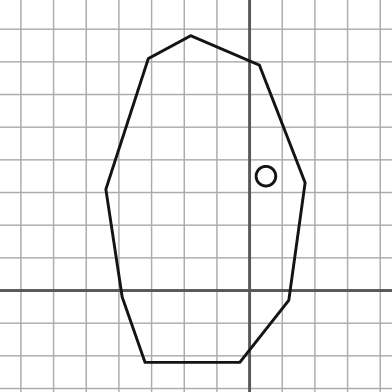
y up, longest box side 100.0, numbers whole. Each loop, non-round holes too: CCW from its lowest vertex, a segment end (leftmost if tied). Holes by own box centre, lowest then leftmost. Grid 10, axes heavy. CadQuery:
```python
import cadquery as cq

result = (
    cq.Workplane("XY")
    .moveTo(-32.0, -22.0)
    .lineTo(-3.0, -22.0)
    .lineTo(12.0, -3.0)
    .lineTo(17.0, 33.0)
    .lineTo(3.0, 69.0)
    .lineTo(-18.0, 78.0)
    .lineTo(-31.0, 71.0)
    .lineTo(-44.0, 31.0)
    .lineTo(-39.0, -2.0)
    .close()
    .moveTo(5.0, 35.0)
    .circle(3.0)
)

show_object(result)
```